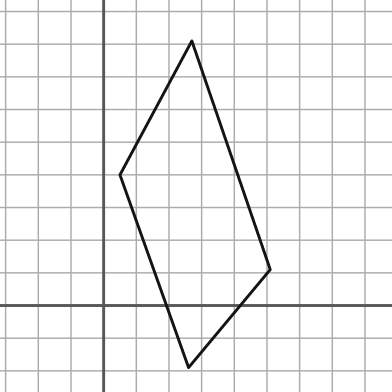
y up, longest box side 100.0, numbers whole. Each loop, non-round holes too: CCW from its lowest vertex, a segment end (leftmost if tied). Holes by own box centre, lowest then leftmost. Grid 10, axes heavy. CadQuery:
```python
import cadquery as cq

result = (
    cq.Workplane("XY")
    .moveTo(26.0, -19.0)
    .lineTo(51.0, 11.0)
    .lineTo(27.0, 81.0)
    .lineTo(5.0, 40.0)
    .close()
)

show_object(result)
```